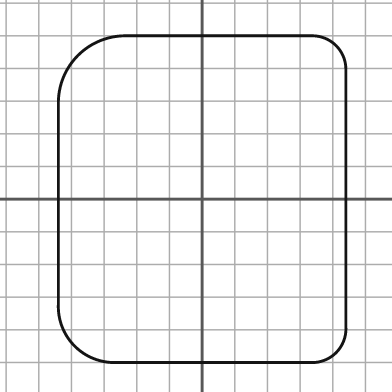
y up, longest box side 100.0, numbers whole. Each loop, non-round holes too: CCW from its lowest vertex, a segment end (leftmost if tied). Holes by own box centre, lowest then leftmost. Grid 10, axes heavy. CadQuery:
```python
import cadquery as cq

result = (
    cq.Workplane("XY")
    .moveTo(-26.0, -50.0)
    .lineTo(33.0, -50.0)
    .threePointArc((41.0, -47.0), (44.0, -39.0))
    .lineTo(44.0, 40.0)
    .threePointArc((41.0, 47.0), (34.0, 50.0))
    .lineTo(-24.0, 50.0)
    .threePointArc((-38.0, 44.0), (-44.0, 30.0))
    .lineTo(-44.0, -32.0)
    .threePointArc((-39.0, -45.0), (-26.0, -50.0))
    .close()
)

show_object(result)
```